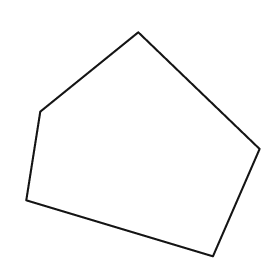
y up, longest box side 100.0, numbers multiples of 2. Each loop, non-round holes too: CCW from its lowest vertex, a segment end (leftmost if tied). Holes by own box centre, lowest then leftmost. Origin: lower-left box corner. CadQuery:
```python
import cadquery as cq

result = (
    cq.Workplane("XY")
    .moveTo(80.0, 0.0)
    .lineTo(100.0, 46.0)
    .lineTo(48.0, 96.0)
    .lineTo(6.0, 62.0)
    .lineTo(0.0, 24.0)
    .close()
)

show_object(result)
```